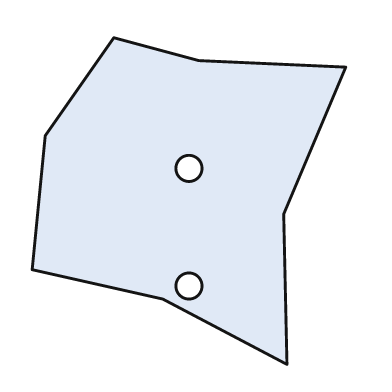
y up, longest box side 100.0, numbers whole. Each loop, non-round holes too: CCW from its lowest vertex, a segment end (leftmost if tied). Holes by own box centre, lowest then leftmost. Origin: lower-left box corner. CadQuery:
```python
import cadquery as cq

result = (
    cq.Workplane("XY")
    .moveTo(78.0, 0.0)
    .lineTo(77.0, 46.0)
    .lineTo(96.0, 91.0)
    .lineTo(51.0, 93.0)
    .lineTo(25.0, 100.0)
    .lineTo(4.0, 70.0)
    .lineTo(0.0, 29.0)
    .lineTo(40.0, 20.0)
    .close()
    .moveTo(48.0, 24.0)
    .circle(4.0)
    .moveTo(48.0, 60.0)
    .circle(4.0)
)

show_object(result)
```